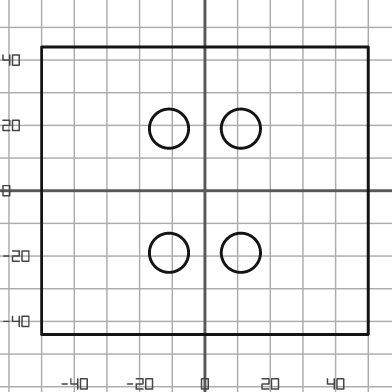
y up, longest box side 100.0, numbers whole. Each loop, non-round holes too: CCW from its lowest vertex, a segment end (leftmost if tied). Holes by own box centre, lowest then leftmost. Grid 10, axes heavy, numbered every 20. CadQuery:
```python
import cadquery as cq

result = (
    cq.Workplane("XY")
    .moveTo(-50.0, -44.0)
    .lineTo(50.0, -44.0)
    .lineTo(50.0, 44.0)
    .lineTo(-50.0, 44.0)
    .close()
    .moveTo(-11.0, -19.0)
    .circle(6.0)
    .moveTo(11.0, -19.0)
    .circle(6.0)
    .moveTo(-11.0, 19.0)
    .circle(6.0)
    .moveTo(11.0, 19.0)
    .circle(6.0)
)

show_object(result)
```